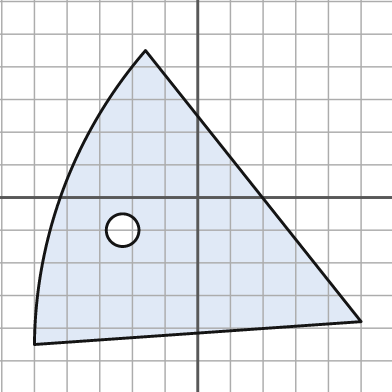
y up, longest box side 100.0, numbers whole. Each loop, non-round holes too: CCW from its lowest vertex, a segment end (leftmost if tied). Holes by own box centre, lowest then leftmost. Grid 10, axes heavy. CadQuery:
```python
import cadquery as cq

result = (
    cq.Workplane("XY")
    .moveTo(-50.0, -45.0)
    .lineTo(50.0, -38.0)
    .lineTo(-16.0, 45.0)
    .threePointArc((-41.0, 3.0), (-50.0, -45.0))
    .close()
    .moveTo(-23.0, -10.0)
    .circle(5.0)
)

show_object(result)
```